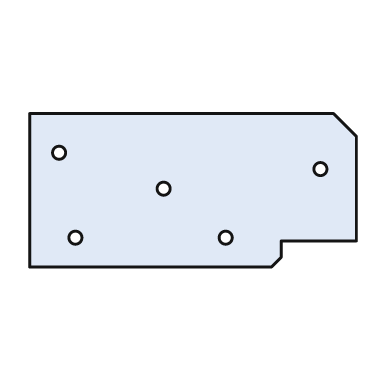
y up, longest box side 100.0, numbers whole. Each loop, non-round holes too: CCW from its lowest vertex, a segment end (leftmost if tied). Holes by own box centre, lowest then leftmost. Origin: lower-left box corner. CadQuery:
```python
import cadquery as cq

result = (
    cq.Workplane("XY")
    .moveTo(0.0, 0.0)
    .lineTo(74.0, 0.0)
    .lineTo(77.0, 3.0)
    .lineTo(77.0, 8.0)
    .lineTo(100.0, 8.0)
    .lineTo(100.0, 40.0)
    .lineTo(93.0, 47.0)
    .lineTo(0.0, 47.0)
    .close()
    .moveTo(14.0, 9.0)
    .circle(2.0)
    .moveTo(60.0, 9.0)
    .circle(2.0)
    .moveTo(41.0, 24.0)
    .circle(2.0)
    .moveTo(89.0, 30.0)
    .circle(2.0)
    .moveTo(9.0, 35.0)
    .circle(2.0)
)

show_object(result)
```